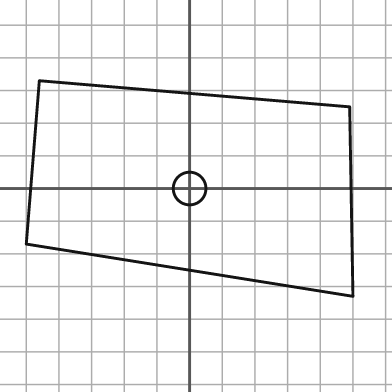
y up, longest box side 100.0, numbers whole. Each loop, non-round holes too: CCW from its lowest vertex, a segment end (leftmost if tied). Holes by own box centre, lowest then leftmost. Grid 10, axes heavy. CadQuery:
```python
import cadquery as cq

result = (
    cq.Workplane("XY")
    .moveTo(50.0, -33.0)
    .lineTo(49.0, 25.0)
    .lineTo(-46.0, 33.0)
    .lineTo(-50.0, -17.0)
    .close()
    .moveTo(0.0, 0.0)
    .circle(5.0)
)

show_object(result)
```